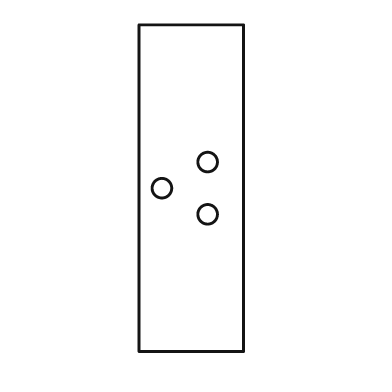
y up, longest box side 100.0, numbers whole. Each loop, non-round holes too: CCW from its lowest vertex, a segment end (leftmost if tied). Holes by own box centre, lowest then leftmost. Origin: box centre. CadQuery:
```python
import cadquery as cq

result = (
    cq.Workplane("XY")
    .moveTo(-16.0, -50.0)
    .lineTo(16.0, -50.0)
    .lineTo(16.0, 50.0)
    .lineTo(-16.0, 50.0)
    .close()
    .moveTo(5.0, -8.0)
    .circle(3.0)
    .moveTo(-9.0, 0.0)
    .circle(3.0)
    .moveTo(5.0, 8.0)
    .circle(3.0)
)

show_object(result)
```